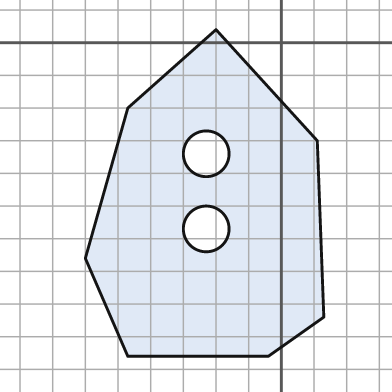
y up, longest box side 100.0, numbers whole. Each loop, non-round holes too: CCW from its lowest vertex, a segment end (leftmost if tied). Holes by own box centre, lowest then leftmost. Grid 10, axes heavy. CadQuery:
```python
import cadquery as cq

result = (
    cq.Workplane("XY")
    .moveTo(-47.0, -96.0)
    .lineTo(-4.0, -96.0)
    .lineTo(13.0, -84.0)
    .lineTo(11.0, -30.0)
    .lineTo(-20.0, 4.0)
    .lineTo(-47.0, -20.0)
    .lineTo(-60.0, -66.0)
    .close()
    .moveTo(-23.0, -57.0)
    .circle(7.0)
    .moveTo(-23.0, -34.0)
    .circle(7.0)
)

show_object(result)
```